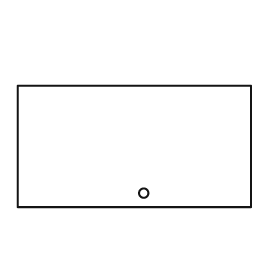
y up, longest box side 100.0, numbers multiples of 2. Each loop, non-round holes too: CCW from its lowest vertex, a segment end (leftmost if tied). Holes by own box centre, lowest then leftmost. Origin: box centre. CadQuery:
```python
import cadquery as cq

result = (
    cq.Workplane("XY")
    .moveTo(-50.0, -26.0)
    .lineTo(50.0, -26.0)
    .lineTo(50.0, 26.0)
    .lineTo(-50.0, 26.0)
    .close()
    .moveTo(4.0, -20.0)
    .circle(2.0)
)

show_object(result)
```